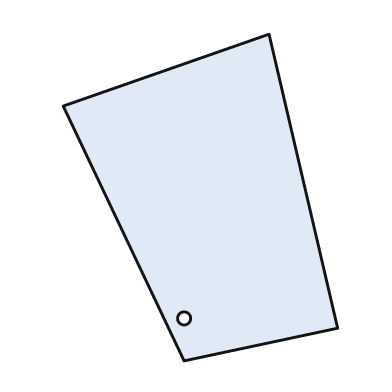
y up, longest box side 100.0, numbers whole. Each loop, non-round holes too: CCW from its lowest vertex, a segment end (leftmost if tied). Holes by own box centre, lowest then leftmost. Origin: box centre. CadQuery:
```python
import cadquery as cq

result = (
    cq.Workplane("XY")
    .moveTo(-5.0, -50.0)
    .lineTo(42.0, -40.0)
    .lineTo(21.0, 50.0)
    .lineTo(-42.0, 28.0)
    .close()
    .moveTo(-5.0, -37.0)
    .circle(2.0)
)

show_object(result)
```